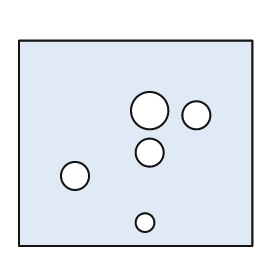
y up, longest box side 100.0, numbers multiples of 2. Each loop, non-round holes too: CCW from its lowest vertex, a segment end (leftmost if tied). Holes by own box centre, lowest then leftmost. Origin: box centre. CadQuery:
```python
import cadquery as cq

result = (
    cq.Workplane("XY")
    .moveTo(-50.0, -44.0)
    .lineTo(50.0, -44.0)
    .lineTo(50.0, 44.0)
    .lineTo(-50.0, 44.0)
    .close()
    .moveTo(4.0, -34.0)
    .circle(4.0)
    .moveTo(-26.0, -14.0)
    .circle(6.0)
    .moveTo(6.0, -4.0)
    .circle(6.0)
    .moveTo(26.0, 12.0)
    .circle(6.0)
    .moveTo(6.0, 14.0)
    .circle(8.0)
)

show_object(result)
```